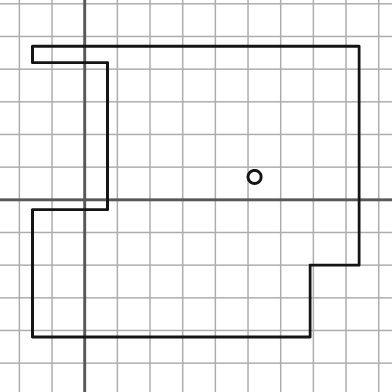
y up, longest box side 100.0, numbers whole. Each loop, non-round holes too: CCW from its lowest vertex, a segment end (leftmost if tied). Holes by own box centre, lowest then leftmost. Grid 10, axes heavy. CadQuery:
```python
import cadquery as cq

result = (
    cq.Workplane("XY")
    .moveTo(-16.0, -42.0)
    .lineTo(69.0, -42.0)
    .lineTo(69.0, -20.0)
    .lineTo(84.0, -20.0)
    .lineTo(84.0, 47.0)
    .lineTo(-16.0, 47.0)
    .lineTo(-16.0, 42.0)
    .lineTo(7.0, 42.0)
    .lineTo(7.0, -3.0)
    .lineTo(-16.0, -3.0)
    .close()
    .moveTo(52.0, 7.0)
    .circle(2.0)
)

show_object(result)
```